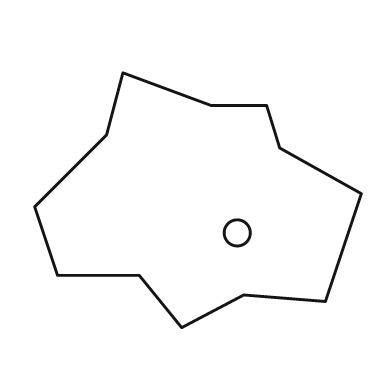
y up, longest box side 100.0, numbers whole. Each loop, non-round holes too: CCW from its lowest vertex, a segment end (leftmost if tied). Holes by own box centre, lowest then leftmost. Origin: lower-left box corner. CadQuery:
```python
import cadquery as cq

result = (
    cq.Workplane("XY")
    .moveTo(45.0, 0.0)
    .lineTo(64.0, 10.0)
    .lineTo(89.0, 8.0)
    .lineTo(100.0, 41.0)
    .lineTo(75.0, 55.0)
    .lineTo(71.0, 68.0)
    .lineTo(54.0, 68.0)
    .lineTo(27.0, 78.0)
    .lineTo(22.0, 59.0)
    .lineTo(0.0, 37.0)
    .lineTo(7.0, 16.0)
    .lineTo(32.0, 16.0)
    .close()
    .moveTo(62.0, 29.0)
    .circle(4.0)
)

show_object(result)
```